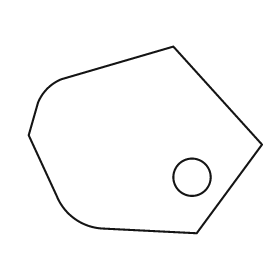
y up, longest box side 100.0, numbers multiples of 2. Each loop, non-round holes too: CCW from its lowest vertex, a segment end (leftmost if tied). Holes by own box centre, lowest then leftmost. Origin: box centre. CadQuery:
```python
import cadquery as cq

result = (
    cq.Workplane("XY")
    .moveTo(22.0, -40.0)
    .lineTo(50.0, -2.0)
    .lineTo(12.0, 40.0)
    .lineTo(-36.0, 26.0)
    .threePointArc((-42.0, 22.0), (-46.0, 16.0))
    .lineTo(-50.0, 2.0)
    .lineTo(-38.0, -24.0)
    .threePointArc((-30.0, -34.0), (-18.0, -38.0))
    .close()
    .moveTo(20.0, -16.0)
    .circle(8.0)
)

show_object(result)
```